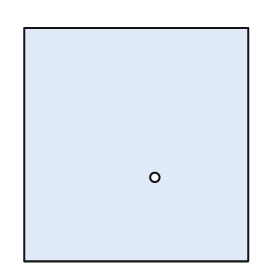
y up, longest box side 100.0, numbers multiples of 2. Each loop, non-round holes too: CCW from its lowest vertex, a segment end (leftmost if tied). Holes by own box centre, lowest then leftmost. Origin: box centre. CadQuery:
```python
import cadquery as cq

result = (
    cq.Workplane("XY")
    .moveTo(-48.0, -50.0)
    .lineTo(48.0, -50.0)
    .lineTo(48.0, 50.0)
    .lineTo(-48.0, 50.0)
    .close()
    .moveTo(8.0, -14.0)
    .circle(2.0)
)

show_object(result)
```